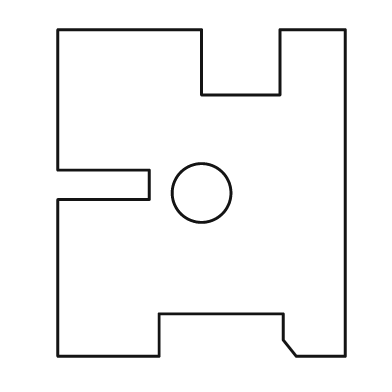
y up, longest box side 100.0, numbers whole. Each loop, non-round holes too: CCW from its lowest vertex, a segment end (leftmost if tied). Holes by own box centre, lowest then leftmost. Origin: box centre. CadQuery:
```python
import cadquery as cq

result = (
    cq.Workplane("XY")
    .moveTo(-44.0, -50.0)
    .lineTo(-13.0, -50.0)
    .lineTo(-13.0, -37.0)
    .lineTo(25.0, -37.0)
    .lineTo(25.0, -45.0)
    .lineTo(29.0, -50.0)
    .lineTo(44.0, -50.0)
    .lineTo(44.0, 50.0)
    .lineTo(24.0, 50.0)
    .lineTo(24.0, 30.0)
    .lineTo(0.0, 30.0)
    .lineTo(0.0, 50.0)
    .lineTo(-44.0, 50.0)
    .lineTo(-44.0, 7.0)
    .lineTo(-16.0, 7.0)
    .lineTo(-16.0, -2.0)
    .lineTo(-44.0, -2.0)
    .close()
    .moveTo(0.0, 0.0)
    .circle(9.0)
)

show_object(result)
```